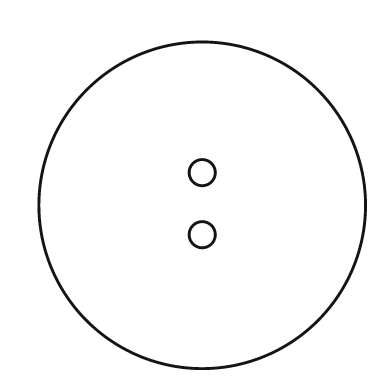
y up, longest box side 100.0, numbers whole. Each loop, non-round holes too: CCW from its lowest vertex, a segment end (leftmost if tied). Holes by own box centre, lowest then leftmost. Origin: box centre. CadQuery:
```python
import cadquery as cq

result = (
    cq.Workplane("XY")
    .moveTo(0.0, 0.0)
    .circle(50.0)
    .moveTo(0.0, -9.0)
    .circle(4.0)
    .moveTo(0.0, 10.0)
    .circle(4.0)
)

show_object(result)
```